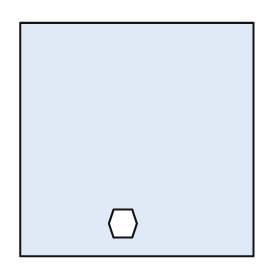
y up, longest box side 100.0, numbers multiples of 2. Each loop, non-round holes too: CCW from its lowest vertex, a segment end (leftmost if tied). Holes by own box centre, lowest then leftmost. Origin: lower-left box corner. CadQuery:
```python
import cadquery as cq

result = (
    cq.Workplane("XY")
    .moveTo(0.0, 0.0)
    .lineTo(100.0, 0.0)
    .lineTo(100.0, 100.0)
    .lineTo(0.0, 100.0)
    .close()
    .moveTo(40.0, 8.0)
    .lineTo(48.0, 8.0)
    .lineTo(50.0, 14.0)
    .lineTo(48.0, 20.0)
    .lineTo(40.0, 20.0)
    .lineTo(38.0, 14.0)
    .close()
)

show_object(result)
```